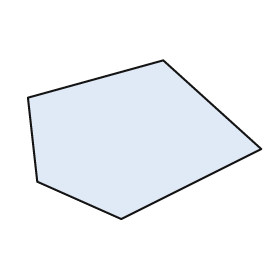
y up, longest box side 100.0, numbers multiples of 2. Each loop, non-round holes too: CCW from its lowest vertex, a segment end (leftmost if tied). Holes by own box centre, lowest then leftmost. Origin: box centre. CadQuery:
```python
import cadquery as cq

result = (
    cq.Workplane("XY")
    .moveTo(-10.0, -34.0)
    .lineTo(50.0, -4.0)
    .lineTo(8.0, 34.0)
    .lineTo(-50.0, 18.0)
    .lineTo(-46.0, -18.0)
    .close()
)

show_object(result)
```